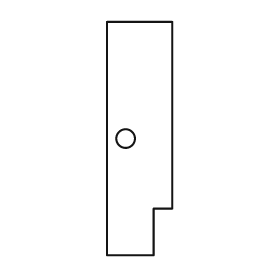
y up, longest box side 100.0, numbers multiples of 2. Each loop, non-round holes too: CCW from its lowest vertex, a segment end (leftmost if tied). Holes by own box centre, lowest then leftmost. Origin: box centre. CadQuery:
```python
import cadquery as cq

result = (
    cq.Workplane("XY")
    .moveTo(-14.0, -50.0)
    .lineTo(6.0, -50.0)
    .lineTo(6.0, -30.0)
    .lineTo(14.0, -30.0)
    .lineTo(14.0, 50.0)
    .lineTo(-14.0, 50.0)
    .close()
    .moveTo(-6.0, 0.0)
    .circle(4.0)
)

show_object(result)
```